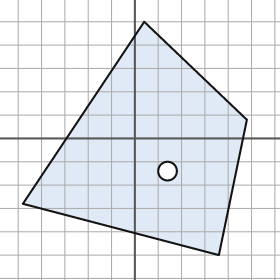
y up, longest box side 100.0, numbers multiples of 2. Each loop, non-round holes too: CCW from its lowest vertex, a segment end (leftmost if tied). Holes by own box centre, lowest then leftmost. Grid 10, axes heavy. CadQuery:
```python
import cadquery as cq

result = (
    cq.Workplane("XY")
    .moveTo(36.0, -50.0)
    .lineTo(48.0, 8.0)
    .lineTo(4.0, 50.0)
    .lineTo(-48.0, -28.0)
    .close()
    .moveTo(14.0, -14.0)
    .circle(4.0)
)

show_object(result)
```